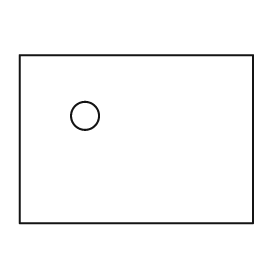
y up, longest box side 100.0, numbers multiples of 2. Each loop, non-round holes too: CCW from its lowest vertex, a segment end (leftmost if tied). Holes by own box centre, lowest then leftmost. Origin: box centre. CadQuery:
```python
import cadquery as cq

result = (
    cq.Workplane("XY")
    .moveTo(-50.0, -36.0)
    .lineTo(50.0, -36.0)
    .lineTo(50.0, 36.0)
    .lineTo(-50.0, 36.0)
    .close()
    .moveTo(-22.0, 10.0)
    .circle(6.0)
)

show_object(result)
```